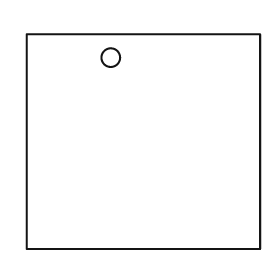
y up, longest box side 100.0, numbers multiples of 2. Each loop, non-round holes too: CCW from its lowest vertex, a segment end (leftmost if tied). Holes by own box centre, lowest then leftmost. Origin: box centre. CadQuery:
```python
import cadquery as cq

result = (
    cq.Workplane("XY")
    .moveTo(-50.0, -46.0)
    .lineTo(50.0, -46.0)
    .lineTo(50.0, 46.0)
    .lineTo(-50.0, 46.0)
    .close()
    .moveTo(-14.0, 36.0)
    .circle(4.0)
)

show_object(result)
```